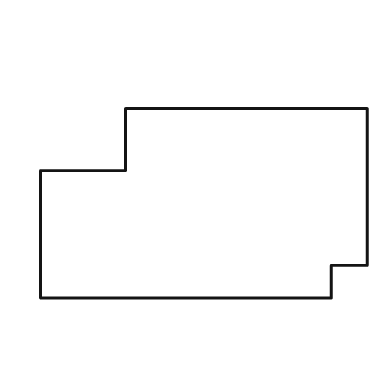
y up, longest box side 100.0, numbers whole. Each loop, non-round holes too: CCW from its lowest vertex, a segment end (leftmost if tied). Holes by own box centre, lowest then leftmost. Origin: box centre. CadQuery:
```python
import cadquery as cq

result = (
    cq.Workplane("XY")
    .moveTo(-50.0, -29.0)
    .lineTo(39.0, -29.0)
    .lineTo(39.0, -19.0)
    .lineTo(50.0, -19.0)
    .lineTo(50.0, 29.0)
    .lineTo(-24.0, 29.0)
    .lineTo(-24.0, 10.0)
    .lineTo(-50.0, 10.0)
    .close()
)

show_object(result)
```